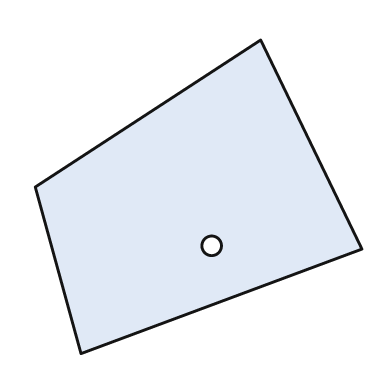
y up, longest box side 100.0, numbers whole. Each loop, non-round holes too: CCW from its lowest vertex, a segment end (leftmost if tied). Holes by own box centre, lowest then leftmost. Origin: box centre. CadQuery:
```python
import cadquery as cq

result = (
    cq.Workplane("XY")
    .moveTo(-36.0, -48.0)
    .lineTo(50.0, -16.0)
    .lineTo(19.0, 48.0)
    .lineTo(-50.0, 3.0)
    .close()
    .moveTo(4.0, -15.0)
    .circle(3.0)
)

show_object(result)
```